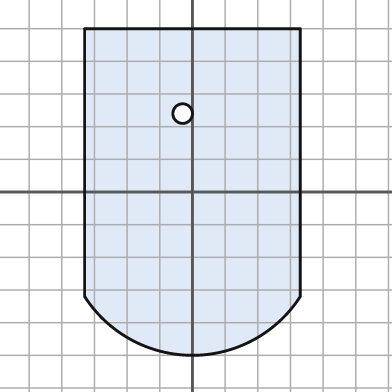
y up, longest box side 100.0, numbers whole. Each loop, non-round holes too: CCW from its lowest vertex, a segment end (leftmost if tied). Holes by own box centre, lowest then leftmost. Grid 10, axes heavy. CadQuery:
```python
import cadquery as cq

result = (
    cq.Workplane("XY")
    .moveTo(-33.0, -32.0)
    .threePointArc((0.0, -50.0), (33.0, -32.0))
    .lineTo(33.0, 50.0)
    .lineTo(-33.0, 50.0)
    .close()
    .moveTo(-3.0, 24.0)
    .circle(3.0)
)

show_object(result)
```